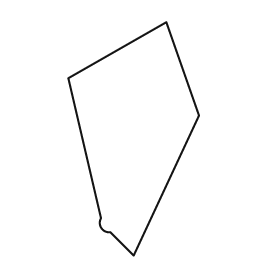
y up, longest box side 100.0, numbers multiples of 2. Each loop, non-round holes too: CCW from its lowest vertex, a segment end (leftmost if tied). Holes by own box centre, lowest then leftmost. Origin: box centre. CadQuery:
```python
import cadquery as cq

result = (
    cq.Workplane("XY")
    .moveTo(0.0, -50.0)
    .lineTo(28.0, 10.0)
    .lineTo(14.0, 50.0)
    .lineTo(-28.0, 26.0)
    .lineTo(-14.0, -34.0)
    .threePointArc((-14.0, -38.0), (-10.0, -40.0))
    .close()
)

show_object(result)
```